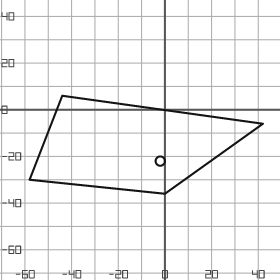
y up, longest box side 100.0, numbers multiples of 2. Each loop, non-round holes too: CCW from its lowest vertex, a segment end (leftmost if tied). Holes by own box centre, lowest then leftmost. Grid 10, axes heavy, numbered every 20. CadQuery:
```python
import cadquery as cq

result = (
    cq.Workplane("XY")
    .moveTo(0.0, -36.0)
    .lineTo(42.0, -6.0)
    .lineTo(-44.0, 6.0)
    .lineTo(-58.0, -30.0)
    .close()
    .moveTo(-2.0, -22.0)
    .circle(2.0)
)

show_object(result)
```